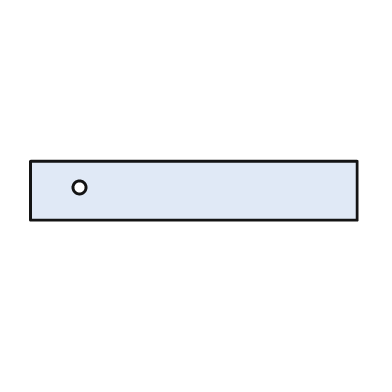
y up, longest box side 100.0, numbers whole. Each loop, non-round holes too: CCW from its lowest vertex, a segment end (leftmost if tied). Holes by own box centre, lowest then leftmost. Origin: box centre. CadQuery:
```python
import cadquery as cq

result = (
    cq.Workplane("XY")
    .moveTo(-50.0, -9.0)
    .lineTo(50.0, -9.0)
    .lineTo(50.0, 9.0)
    .lineTo(-50.0, 9.0)
    .close()
    .moveTo(-35.0, 1.0)
    .circle(2.0)
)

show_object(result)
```